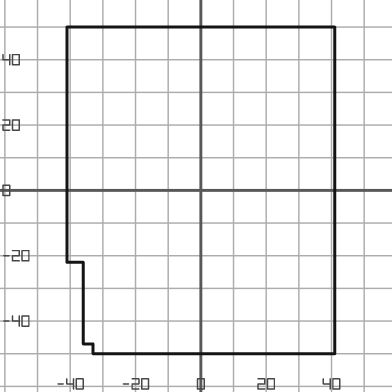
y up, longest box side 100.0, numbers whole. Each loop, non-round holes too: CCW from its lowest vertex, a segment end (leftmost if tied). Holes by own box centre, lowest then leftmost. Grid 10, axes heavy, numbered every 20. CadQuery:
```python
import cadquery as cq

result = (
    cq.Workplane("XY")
    .moveTo(-33.0, -50.0)
    .lineTo(41.0, -50.0)
    .lineTo(41.0, 50.0)
    .lineTo(-41.0, 50.0)
    .lineTo(-41.0, -22.0)
    .lineTo(-36.0, -22.0)
    .lineTo(-36.0, -47.0)
    .lineTo(-33.0, -47.0)
    .close()
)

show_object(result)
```